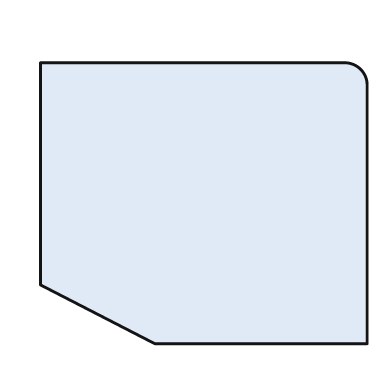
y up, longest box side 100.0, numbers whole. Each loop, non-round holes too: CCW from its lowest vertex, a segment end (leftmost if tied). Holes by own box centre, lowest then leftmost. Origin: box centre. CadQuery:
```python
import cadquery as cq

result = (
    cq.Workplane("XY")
    .moveTo(-15.0, -43.0)
    .lineTo(50.0, -43.0)
    .lineTo(50.0, 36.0)
    .threePointArc((48.0, 41.0), (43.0, 43.0))
    .lineTo(-50.0, 43.0)
    .lineTo(-50.0, -25.0)
    .close()
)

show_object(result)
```